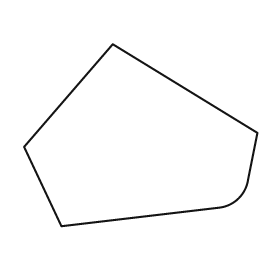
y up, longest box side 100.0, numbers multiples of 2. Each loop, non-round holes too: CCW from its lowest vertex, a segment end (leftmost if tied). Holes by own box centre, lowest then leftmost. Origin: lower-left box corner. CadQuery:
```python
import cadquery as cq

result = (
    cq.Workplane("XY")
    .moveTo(16.0, 0.0)
    .lineTo(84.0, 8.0)
    .threePointArc((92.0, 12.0), (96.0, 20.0))
    .lineTo(100.0, 40.0)
    .lineTo(38.0, 78.0)
    .lineTo(0.0, 34.0)
    .close()
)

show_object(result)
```